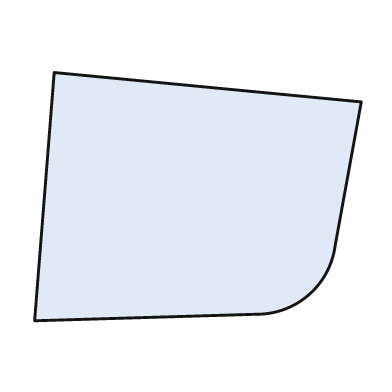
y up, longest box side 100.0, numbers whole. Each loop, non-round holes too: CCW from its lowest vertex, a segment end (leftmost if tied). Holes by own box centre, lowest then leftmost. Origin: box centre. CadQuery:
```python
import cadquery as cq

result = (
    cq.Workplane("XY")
    .moveTo(-50.0, -38.0)
    .lineTo(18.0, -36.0)
    .threePointArc((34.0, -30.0), (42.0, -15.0))
    .lineTo(50.0, 29.0)
    .lineTo(-44.0, 38.0)
    .close()
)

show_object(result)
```